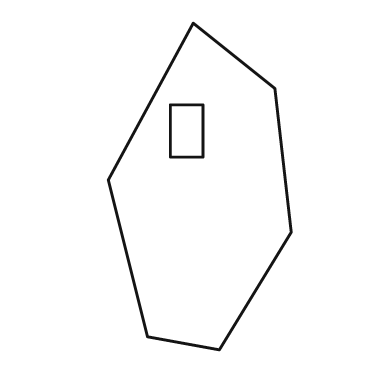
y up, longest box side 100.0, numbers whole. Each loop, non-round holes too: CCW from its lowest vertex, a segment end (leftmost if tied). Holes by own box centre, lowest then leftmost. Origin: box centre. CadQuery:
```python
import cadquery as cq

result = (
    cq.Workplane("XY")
    .moveTo(6.0, -50.0)
    .lineTo(28.0, -14.0)
    .lineTo(23.0, 30.0)
    .lineTo(-2.0, 50.0)
    .lineTo(-28.0, 2.0)
    .lineTo(-16.0, -46.0)
    .close()
    .moveTo(-9.0, 9.0)
    .lineTo(1.0, 9.0)
    .lineTo(1.0, 25.0)
    .lineTo(-9.0, 25.0)
    .close()
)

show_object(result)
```